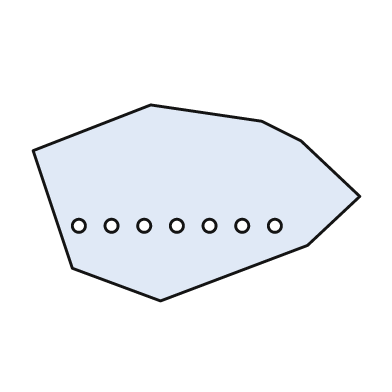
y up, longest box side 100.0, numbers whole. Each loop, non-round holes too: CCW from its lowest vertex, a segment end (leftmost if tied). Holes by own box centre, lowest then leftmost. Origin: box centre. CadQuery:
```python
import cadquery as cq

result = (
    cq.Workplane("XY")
    .moveTo(-11.0, -30.0)
    .lineTo(34.0, -13.0)
    .lineTo(50.0, 2.0)
    .lineTo(32.0, 19.0)
    .lineTo(20.0, 25.0)
    .lineTo(-14.0, 30.0)
    .lineTo(-50.0, 16.0)
    .lineTo(-38.0, -20.0)
    .close()
    .moveTo(-36.0, -7.0)
    .circle(2.0)
    .moveTo(-26.0, -7.0)
    .circle(2.0)
    .moveTo(-16.0, -7.0)
    .circle(2.0)
    .moveTo(-6.0, -7.0)
    .circle(2.0)
    .moveTo(4.0, -7.0)
    .circle(2.0)
    .moveTo(14.0, -7.0)
    .circle(2.0)
    .moveTo(24.0, -7.0)
    .circle(2.0)
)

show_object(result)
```